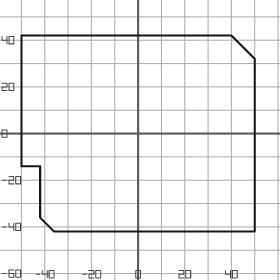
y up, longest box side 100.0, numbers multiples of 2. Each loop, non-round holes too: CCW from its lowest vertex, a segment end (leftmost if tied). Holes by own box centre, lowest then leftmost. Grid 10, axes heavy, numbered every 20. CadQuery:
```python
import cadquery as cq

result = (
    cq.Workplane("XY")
    .moveTo(-36.0, -42.0)
    .lineTo(50.0, -42.0)
    .lineTo(50.0, 32.0)
    .lineTo(40.0, 42.0)
    .lineTo(-50.0, 42.0)
    .lineTo(-50.0, -14.0)
    .lineTo(-42.0, -14.0)
    .lineTo(-42.0, -36.0)
    .close()
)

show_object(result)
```